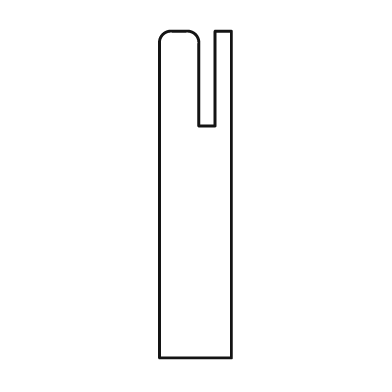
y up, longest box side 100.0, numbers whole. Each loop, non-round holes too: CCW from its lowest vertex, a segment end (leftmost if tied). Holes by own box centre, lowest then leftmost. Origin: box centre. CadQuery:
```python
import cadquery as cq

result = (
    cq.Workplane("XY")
    .moveTo(-11.0, -50.0)
    .lineTo(11.0, -50.0)
    .lineTo(11.0, 50.0)
    .lineTo(6.0, 50.0)
    .lineTo(6.0, 21.0)
    .lineTo(1.0, 21.0)
    .lineTo(1.0, 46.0)
    .threePointArc((0.0, 49.0), (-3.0, 50.0))
    .lineTo(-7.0, 50.0)
    .threePointArc((-10.0, 49.0), (-11.0, 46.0))
    .close()
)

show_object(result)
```